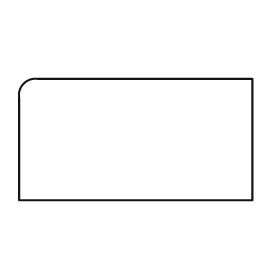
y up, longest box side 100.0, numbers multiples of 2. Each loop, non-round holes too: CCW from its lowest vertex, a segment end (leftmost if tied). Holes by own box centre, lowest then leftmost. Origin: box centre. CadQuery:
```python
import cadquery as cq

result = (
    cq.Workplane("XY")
    .moveTo(-50.0, -26.0)
    .lineTo(50.0, -26.0)
    .lineTo(50.0, 26.0)
    .lineTo(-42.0, 26.0)
    .threePointArc((-48.0, 24.0), (-50.0, 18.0))
    .close()
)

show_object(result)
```